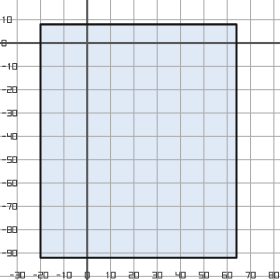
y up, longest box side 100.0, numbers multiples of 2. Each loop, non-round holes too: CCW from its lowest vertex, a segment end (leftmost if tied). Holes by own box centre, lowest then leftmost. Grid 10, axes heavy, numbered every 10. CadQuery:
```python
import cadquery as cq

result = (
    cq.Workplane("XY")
    .moveTo(-20.0, -92.0)
    .lineTo(64.0, -92.0)
    .lineTo(64.0, 8.0)
    .lineTo(-20.0, 8.0)
    .close()
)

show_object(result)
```